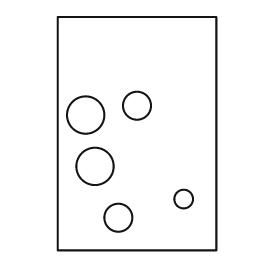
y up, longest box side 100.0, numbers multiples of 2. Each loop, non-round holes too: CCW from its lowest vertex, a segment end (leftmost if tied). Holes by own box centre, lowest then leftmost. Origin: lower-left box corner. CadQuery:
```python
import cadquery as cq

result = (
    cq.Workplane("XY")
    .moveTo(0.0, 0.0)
    .lineTo(68.0, 0.0)
    .lineTo(68.0, 100.0)
    .lineTo(0.0, 100.0)
    .close()
    .moveTo(26.0, 14.0)
    .circle(6.0)
    .moveTo(54.0, 22.0)
    .circle(4.0)
    .moveTo(16.0, 36.0)
    .circle(8.0)
    .moveTo(12.0, 58.0)
    .circle(8.0)
    .moveTo(34.0, 62.0)
    .circle(6.0)
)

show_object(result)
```